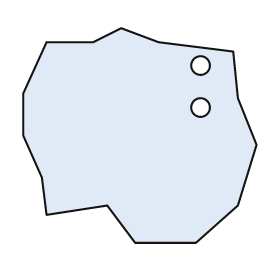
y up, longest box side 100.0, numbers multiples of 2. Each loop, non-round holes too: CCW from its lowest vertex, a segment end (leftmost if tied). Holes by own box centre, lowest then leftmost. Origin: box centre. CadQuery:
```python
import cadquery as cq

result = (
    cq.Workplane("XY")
    .moveTo(-2.0, -46.0)
    .lineTo(24.0, -46.0)
    .lineTo(42.0, -30.0)
    .lineTo(50.0, -4.0)
    .lineTo(42.0, 16.0)
    .lineTo(40.0, 36.0)
    .lineTo(8.0, 40.0)
    .lineTo(-8.0, 46.0)
    .lineTo(-20.0, 40.0)
    .lineTo(-40.0, 40.0)
    .lineTo(-50.0, 18.0)
    .lineTo(-50.0, 0.0)
    .lineTo(-42.0, -18.0)
    .lineTo(-40.0, -34.0)
    .lineTo(-14.0, -30.0)
    .close()
    .moveTo(26.0, 12.0)
    .circle(4.0)
    .moveTo(26.0, 30.0)
    .circle(4.0)
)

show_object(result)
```